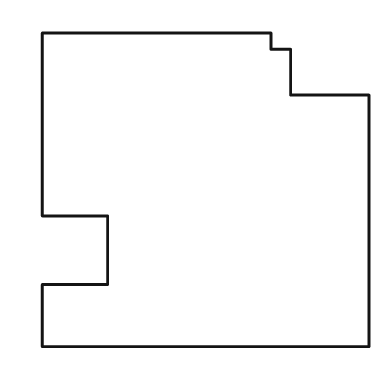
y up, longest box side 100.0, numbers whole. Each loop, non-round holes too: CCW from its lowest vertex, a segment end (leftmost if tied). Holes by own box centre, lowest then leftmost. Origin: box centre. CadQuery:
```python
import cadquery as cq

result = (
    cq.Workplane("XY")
    .moveTo(-50.0, -48.0)
    .lineTo(50.0, -48.0)
    .lineTo(50.0, 29.0)
    .lineTo(26.0, 29.0)
    .lineTo(26.0, 43.0)
    .lineTo(20.0, 43.0)
    .lineTo(20.0, 48.0)
    .lineTo(-50.0, 48.0)
    .lineTo(-50.0, -8.0)
    .lineTo(-30.0, -8.0)
    .lineTo(-30.0, -29.0)
    .lineTo(-50.0, -29.0)
    .close()
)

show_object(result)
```